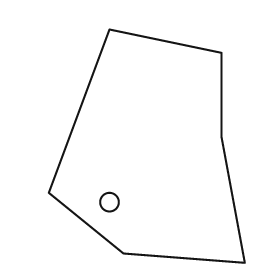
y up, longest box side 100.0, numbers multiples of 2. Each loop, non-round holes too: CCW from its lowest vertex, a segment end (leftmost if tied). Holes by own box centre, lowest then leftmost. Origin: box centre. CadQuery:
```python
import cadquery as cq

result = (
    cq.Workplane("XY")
    .moveTo(42.0, -50.0)
    .lineTo(32.0, 4.0)
    .lineTo(32.0, 40.0)
    .lineTo(-16.0, 50.0)
    .lineTo(-42.0, -20.0)
    .lineTo(-10.0, -46.0)
    .close()
    .moveTo(-16.0, -24.0)
    .circle(4.0)
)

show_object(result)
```